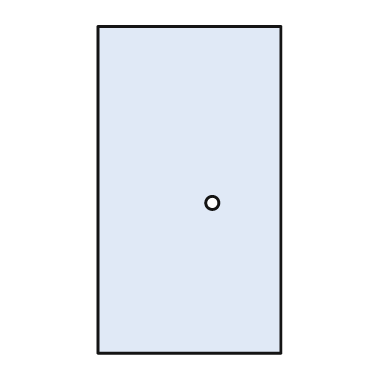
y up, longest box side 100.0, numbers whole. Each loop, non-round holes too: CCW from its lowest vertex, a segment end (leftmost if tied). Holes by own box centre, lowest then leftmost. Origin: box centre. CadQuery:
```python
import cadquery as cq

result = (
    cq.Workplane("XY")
    .moveTo(-28.0, -50.0)
    .lineTo(28.0, -50.0)
    .lineTo(28.0, 50.0)
    .lineTo(-28.0, 50.0)
    .close()
    .moveTo(7.0, -4.0)
    .circle(2.0)
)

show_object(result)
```